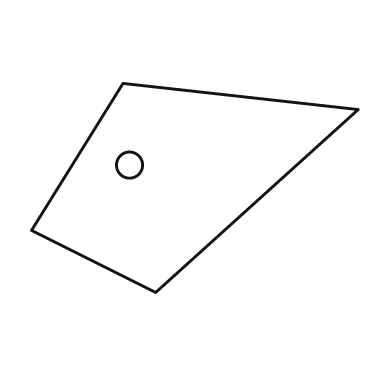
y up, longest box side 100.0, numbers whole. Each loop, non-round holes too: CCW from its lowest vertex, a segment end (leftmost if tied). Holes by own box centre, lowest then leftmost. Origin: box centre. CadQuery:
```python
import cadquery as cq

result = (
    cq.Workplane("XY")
    .moveTo(-12.0, -32.0)
    .lineTo(50.0, 24.0)
    .lineTo(-22.0, 32.0)
    .lineTo(-50.0, -13.0)
    .close()
    .moveTo(-20.0, 7.0)
    .circle(4.0)
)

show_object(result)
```